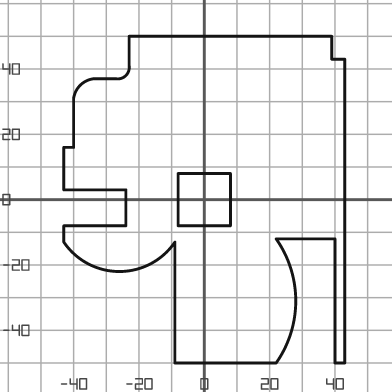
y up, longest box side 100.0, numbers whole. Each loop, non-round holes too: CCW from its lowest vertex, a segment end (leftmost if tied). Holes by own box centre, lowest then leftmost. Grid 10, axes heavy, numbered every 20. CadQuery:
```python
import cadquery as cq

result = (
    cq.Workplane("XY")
    .moveTo(-9.0, -50.0)
    .lineTo(22.0, -50.0)
    .threePointArc((28.0, -31.0), (22.0, -12.0))
    .lineTo(40.0, -12.0)
    .lineTo(40.0, -50.0)
    .lineTo(43.0, -50.0)
    .lineTo(43.0, 43.0)
    .lineTo(39.0, 43.0)
    .lineTo(39.0, 50.0)
    .lineTo(-23.0, 50.0)
    .lineTo(-23.0, 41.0)
    .threePointArc((-24.0, 38.0), (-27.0, 37.0))
    .lineTo(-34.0, 37.0)
    .threePointArc((-38.0, 35.0), (-40.0, 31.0))
    .lineTo(-40.0, 16.0)
    .lineTo(-43.0, 16.0)
    .lineTo(-43.0, 3.0)
    .lineTo(-24.0, 3.0)
    .lineTo(-24.0, -8.0)
    .lineTo(-43.0, -8.0)
    .lineTo(-43.0, -13.0)
    .threePointArc((-26.0, -22.0), (-9.0, -13.0))
    .close()
    .moveTo(-8.0, -8.0)
    .lineTo(8.0, -8.0)
    .lineTo(8.0, 8.0)
    .lineTo(-8.0, 8.0)
    .close()
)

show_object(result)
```